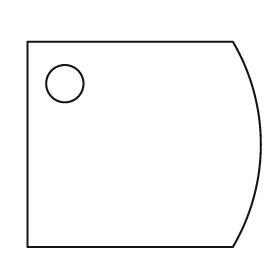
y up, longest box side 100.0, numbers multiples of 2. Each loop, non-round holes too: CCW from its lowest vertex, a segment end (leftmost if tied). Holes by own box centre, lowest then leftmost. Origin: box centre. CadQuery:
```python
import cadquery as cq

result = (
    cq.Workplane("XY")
    .moveTo(-50.0, -44.0)
    .lineTo(38.0, -44.0)
    .threePointArc((50.0, 0.0), (38.0, 44.0))
    .lineTo(-50.0, 44.0)
    .close()
    .moveTo(-34.0, 26.0)
    .circle(8.0)
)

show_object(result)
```